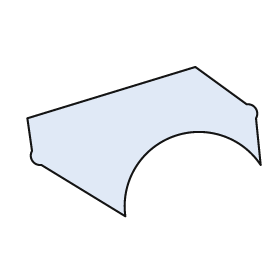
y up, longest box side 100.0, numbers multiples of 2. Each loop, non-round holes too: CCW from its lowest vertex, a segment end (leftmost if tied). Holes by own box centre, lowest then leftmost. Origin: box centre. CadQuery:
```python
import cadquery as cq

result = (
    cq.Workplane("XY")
    .moveTo(-8.0, -32.0)
    .threePointArc((12.0, 2.0), (50.0, -10.0))
    .lineTo(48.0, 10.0)
    .threePointArc((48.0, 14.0), (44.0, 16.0))
    .lineTo(22.0, 32.0)
    .lineTo(-50.0, 10.0)
    .lineTo(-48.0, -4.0)
    .threePointArc((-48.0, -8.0), (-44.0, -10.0))
    .close()
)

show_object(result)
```